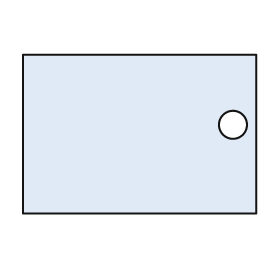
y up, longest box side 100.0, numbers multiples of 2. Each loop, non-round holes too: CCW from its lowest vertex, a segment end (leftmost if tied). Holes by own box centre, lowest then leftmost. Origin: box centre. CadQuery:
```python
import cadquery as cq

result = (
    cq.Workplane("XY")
    .moveTo(-50.0, -34.0)
    .lineTo(50.0, -34.0)
    .lineTo(50.0, 34.0)
    .lineTo(-50.0, 34.0)
    .close()
    .moveTo(40.0, 4.0)
    .circle(6.0)
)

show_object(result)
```